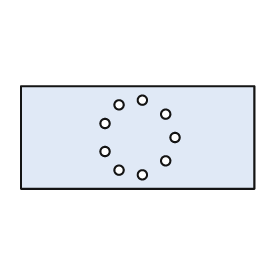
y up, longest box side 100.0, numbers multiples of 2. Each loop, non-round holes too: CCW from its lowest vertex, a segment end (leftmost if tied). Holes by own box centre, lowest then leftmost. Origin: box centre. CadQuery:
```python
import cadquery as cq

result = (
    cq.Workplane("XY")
    .moveTo(-50.0, -22.0)
    .lineTo(50.0, -22.0)
    .lineTo(50.0, 22.0)
    .lineTo(-50.0, 22.0)
    .close()
    .moveTo(2.0, -16.0)
    .circle(2.0)
    .moveTo(-8.0, -14.0)
    .circle(2.0)
    .moveTo(12.0, -10.0)
    .circle(2.0)
    .moveTo(-14.0, -6.0)
    .circle(2.0)
    .moveTo(16.0, 0.0)
    .circle(2.0)
    .moveTo(-14.0, 6.0)
    .circle(2.0)
    .moveTo(12.0, 10.0)
    .circle(2.0)
    .moveTo(-8.0, 14.0)
    .circle(2.0)
    .moveTo(2.0, 16.0)
    .circle(2.0)
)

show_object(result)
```